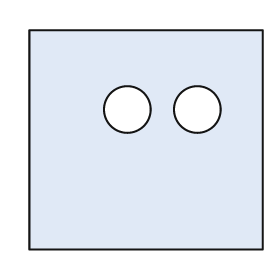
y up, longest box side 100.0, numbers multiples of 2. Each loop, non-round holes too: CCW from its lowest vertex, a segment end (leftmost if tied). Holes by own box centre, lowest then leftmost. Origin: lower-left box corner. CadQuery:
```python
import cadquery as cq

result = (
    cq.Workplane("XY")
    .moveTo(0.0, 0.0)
    .lineTo(100.0, 0.0)
    .lineTo(100.0, 94.0)
    .lineTo(0.0, 94.0)
    .close()
    .moveTo(42.0, 60.0)
    .circle(10.0)
    .moveTo(72.0, 60.0)
    .circle(10.0)
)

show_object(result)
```